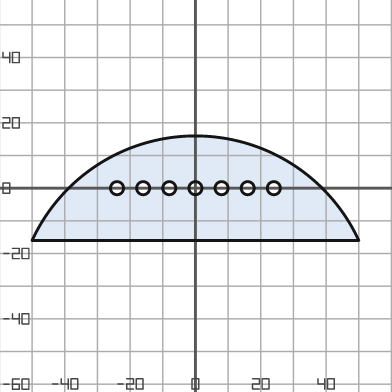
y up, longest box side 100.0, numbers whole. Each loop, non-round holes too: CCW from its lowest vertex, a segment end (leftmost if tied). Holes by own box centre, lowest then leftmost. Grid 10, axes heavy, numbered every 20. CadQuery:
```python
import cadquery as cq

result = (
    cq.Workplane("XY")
    .moveTo(-50.0, -16.0)
    .lineTo(50.0, -16.0)
    .threePointArc((0.0, 16.0), (-50.0, -16.0))
    .close()
    .moveTo(-24.0, 0.0)
    .circle(2.0)
    .moveTo(-16.0, 0.0)
    .circle(2.0)
    .moveTo(-8.0, 0.0)
    .circle(2.0)
    .moveTo(0.0, 0.0)
    .circle(2.0)
    .moveTo(8.0, 0.0)
    .circle(2.0)
    .moveTo(16.0, 0.0)
    .circle(2.0)
    .moveTo(24.0, 0.0)
    .circle(2.0)
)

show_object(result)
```